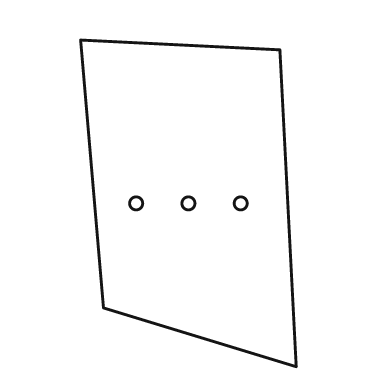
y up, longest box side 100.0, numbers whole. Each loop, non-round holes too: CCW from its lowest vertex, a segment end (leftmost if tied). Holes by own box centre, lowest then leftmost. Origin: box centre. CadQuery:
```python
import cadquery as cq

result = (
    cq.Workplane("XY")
    .moveTo(33.0, -50.0)
    .lineTo(28.0, 47.0)
    .lineTo(-33.0, 50.0)
    .lineTo(-26.0, -32.0)
    .close()
    .moveTo(-16.0, 0.0)
    .circle(2.0)
    .moveTo(0.0, 0.0)
    .circle(2.0)
    .moveTo(16.0, 0.0)
    .circle(2.0)
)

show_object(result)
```